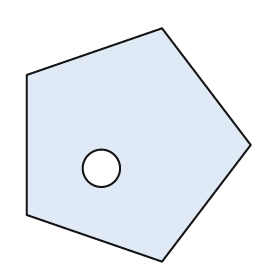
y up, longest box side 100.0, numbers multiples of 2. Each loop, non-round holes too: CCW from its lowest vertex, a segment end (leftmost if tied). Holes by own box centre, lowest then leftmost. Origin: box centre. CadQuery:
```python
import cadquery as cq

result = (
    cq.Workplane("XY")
    .moveTo(10.0, -50.0)
    .lineTo(48.0, 0.0)
    .lineTo(10.0, 50.0)
    .lineTo(-48.0, 30.0)
    .lineTo(-48.0, -30.0)
    .close()
    .moveTo(-16.0, -10.0)
    .circle(8.0)
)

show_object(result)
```